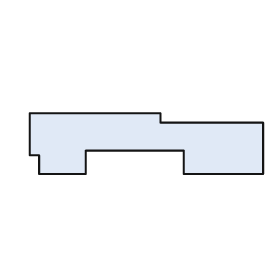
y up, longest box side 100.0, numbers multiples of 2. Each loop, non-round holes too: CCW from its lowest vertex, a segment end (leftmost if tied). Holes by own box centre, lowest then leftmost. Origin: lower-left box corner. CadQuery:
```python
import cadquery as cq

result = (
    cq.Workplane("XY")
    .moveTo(4.0, 0.0)
    .lineTo(24.0, 0.0)
    .lineTo(24.0, 10.0)
    .lineTo(66.0, 10.0)
    .lineTo(66.0, 0.0)
    .lineTo(100.0, 0.0)
    .lineTo(100.0, 22.0)
    .lineTo(56.0, 22.0)
    .lineTo(56.0, 26.0)
    .lineTo(0.0, 26.0)
    .lineTo(0.0, 8.0)
    .lineTo(4.0, 8.0)
    .close()
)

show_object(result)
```